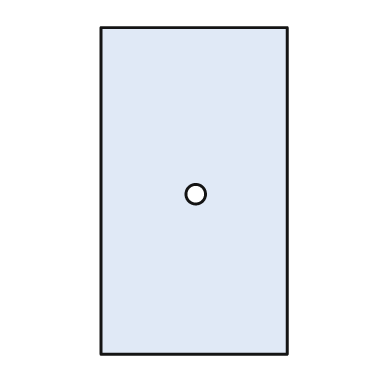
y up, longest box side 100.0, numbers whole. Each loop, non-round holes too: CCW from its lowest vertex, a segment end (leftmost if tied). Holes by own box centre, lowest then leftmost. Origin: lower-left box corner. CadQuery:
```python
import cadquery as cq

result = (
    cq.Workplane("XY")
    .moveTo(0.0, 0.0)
    .lineTo(57.0, 0.0)
    .lineTo(57.0, 100.0)
    .lineTo(0.0, 100.0)
    .close()
    .moveTo(29.0, 49.0)
    .circle(3.0)
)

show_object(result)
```